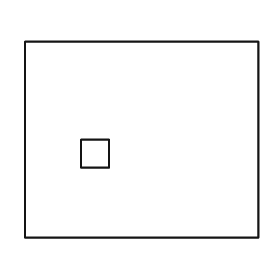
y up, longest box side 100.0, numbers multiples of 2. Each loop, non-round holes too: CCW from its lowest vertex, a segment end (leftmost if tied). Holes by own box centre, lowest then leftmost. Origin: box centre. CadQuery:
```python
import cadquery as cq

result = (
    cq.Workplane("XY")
    .moveTo(-50.0, -42.0)
    .lineTo(50.0, -42.0)
    .lineTo(50.0, 42.0)
    .lineTo(-50.0, 42.0)
    .close()
    .moveTo(-26.0, -12.0)
    .lineTo(-14.0, -12.0)
    .lineTo(-14.0, 0.0)
    .lineTo(-26.0, 0.0)
    .close()
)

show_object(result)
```